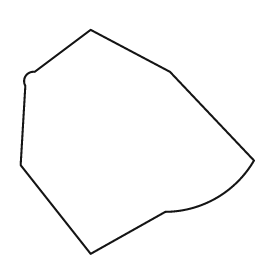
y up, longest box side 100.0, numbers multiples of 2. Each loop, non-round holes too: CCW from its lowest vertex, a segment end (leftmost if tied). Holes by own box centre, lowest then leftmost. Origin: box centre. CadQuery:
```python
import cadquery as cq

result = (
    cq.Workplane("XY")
    .moveTo(-20.0, -48.0)
    .lineTo(12.0, -30.0)
    .threePointArc((34.0, -24.0), (50.0, -8.0))
    .lineTo(14.0, 30.0)
    .lineTo(-20.0, 48.0)
    .lineTo(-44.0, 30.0)
    .threePointArc((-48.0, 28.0), (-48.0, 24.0))
    .lineTo(-50.0, -10.0)
    .close()
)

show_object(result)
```